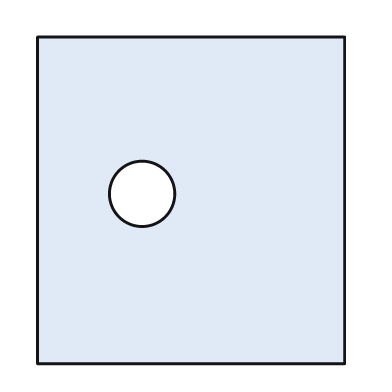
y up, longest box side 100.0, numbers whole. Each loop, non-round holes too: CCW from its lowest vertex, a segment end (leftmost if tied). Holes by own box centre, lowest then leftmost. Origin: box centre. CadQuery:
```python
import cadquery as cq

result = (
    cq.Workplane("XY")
    .moveTo(-47.0, -50.0)
    .lineTo(47.0, -50.0)
    .lineTo(47.0, 50.0)
    .lineTo(-47.0, 50.0)
    .close()
    .moveTo(-15.0, 2.0)
    .circle(10.0)
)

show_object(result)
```